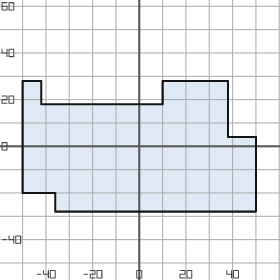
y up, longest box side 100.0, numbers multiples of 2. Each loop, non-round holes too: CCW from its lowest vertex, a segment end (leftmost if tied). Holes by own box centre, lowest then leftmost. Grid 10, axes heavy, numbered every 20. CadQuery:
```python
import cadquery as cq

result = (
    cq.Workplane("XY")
    .moveTo(-36.0, -28.0)
    .lineTo(50.0, -28.0)
    .lineTo(50.0, 4.0)
    .lineTo(38.0, 4.0)
    .lineTo(38.0, 28.0)
    .lineTo(10.0, 28.0)
    .lineTo(10.0, 18.0)
    .lineTo(-42.0, 18.0)
    .lineTo(-42.0, 28.0)
    .lineTo(-50.0, 28.0)
    .lineTo(-50.0, -20.0)
    .lineTo(-36.0, -20.0)
    .close()
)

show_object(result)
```